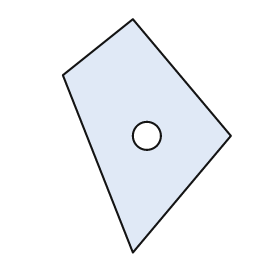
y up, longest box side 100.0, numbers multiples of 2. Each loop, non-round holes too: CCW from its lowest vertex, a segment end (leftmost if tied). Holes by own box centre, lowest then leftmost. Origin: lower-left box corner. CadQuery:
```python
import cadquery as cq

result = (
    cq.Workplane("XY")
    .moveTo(30.0, 0.0)
    .lineTo(72.0, 50.0)
    .lineTo(30.0, 100.0)
    .lineTo(0.0, 76.0)
    .close()
    .moveTo(36.0, 50.0)
    .circle(6.0)
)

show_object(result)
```